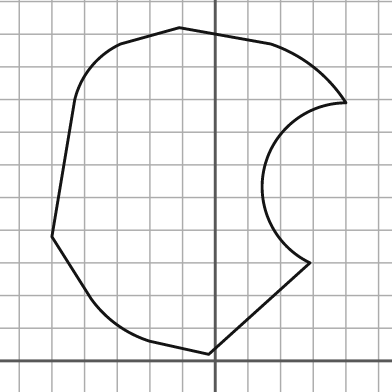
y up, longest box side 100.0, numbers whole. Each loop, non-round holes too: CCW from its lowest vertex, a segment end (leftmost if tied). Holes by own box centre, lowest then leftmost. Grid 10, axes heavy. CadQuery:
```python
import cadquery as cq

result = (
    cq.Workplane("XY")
    .moveTo(-2.0, 2.0)
    .lineTo(29.0, 30.0)
    .threePointArc((15.0, 59.0), (40.0, 79.0))
    .threePointArc((30.0, 90.0), (17.0, 97.0))
    .lineTo(-11.0, 102.0)
    .lineTo(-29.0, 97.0)
    .threePointArc((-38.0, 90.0), (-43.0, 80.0))
    .lineTo(-50.0, 38.0)
    .lineTo(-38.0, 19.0)
    .threePointArc((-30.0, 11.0), (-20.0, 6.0))
    .close()
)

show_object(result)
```